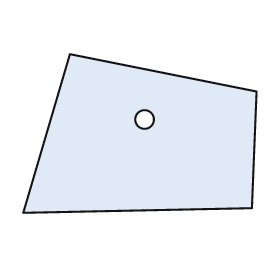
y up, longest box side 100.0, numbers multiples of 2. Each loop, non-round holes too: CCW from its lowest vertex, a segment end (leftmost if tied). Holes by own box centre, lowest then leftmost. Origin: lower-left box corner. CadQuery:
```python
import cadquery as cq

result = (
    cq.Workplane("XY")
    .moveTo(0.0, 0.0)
    .lineTo(98.0, 2.0)
    .lineTo(100.0, 52.0)
    .lineTo(20.0, 68.0)
    .close()
    .moveTo(52.0, 40.0)
    .circle(4.0)
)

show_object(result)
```